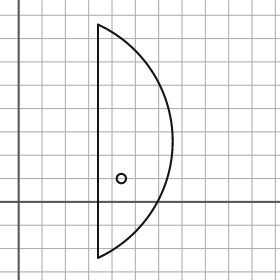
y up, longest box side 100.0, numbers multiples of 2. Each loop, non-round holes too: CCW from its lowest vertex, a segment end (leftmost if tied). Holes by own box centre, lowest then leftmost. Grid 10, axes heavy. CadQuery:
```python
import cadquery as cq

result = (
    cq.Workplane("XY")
    .moveTo(34.0, -24.0)
    .threePointArc((66.0, 26.0), (34.0, 76.0))
    .close()
    .moveTo(44.0, 10.0)
    .circle(2.0)
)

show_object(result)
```